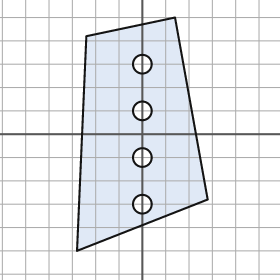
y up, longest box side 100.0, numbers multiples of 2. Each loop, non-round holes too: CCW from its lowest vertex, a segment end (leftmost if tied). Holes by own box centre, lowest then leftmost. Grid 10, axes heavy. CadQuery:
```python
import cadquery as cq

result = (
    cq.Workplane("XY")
    .moveTo(-28.0, -50.0)
    .lineTo(28.0, -28.0)
    .lineTo(14.0, 50.0)
    .lineTo(-24.0, 42.0)
    .close()
    .moveTo(0.0, -30.0)
    .circle(4.0)
    .moveTo(0.0, -10.0)
    .circle(4.0)
    .moveTo(0.0, 10.0)
    .circle(4.0)
    .moveTo(0.0, 30.0)
    .circle(4.0)
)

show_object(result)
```